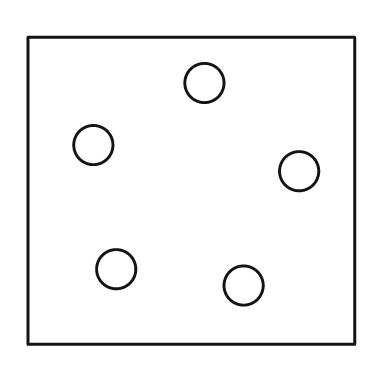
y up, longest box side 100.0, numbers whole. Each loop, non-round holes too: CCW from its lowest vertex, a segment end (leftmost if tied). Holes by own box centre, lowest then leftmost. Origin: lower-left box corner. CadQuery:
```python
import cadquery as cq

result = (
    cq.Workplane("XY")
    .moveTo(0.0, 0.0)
    .lineTo(100.0, 0.0)
    .lineTo(100.0, 94.0)
    .lineTo(0.0, 94.0)
    .close()
    .moveTo(66.0, 18.0)
    .circle(6.0)
    .moveTo(27.0, 23.0)
    .circle(6.0)
    .moveTo(83.0, 53.0)
    .circle(6.0)
    .moveTo(20.0, 61.0)
    .circle(6.0)
    .moveTo(54.0, 80.0)
    .circle(6.0)
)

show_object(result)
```